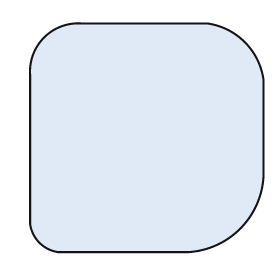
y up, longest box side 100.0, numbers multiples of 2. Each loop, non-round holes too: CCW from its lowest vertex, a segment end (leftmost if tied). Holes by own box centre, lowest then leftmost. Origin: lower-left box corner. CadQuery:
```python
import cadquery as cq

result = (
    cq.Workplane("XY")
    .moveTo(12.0, 0.0)
    .lineTo(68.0, 0.0)
    .threePointArc((90.0, 10.0), (100.0, 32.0))
    .lineTo(100.0, 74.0)
    .threePointArc((92.0, 90.0), (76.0, 98.0))
    .lineTo(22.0, 98.0)
    .threePointArc((6.0, 92.0), (0.0, 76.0))
    .lineTo(0.0, 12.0)
    .threePointArc((4.0, 4.0), (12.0, 0.0))
    .close()
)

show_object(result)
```